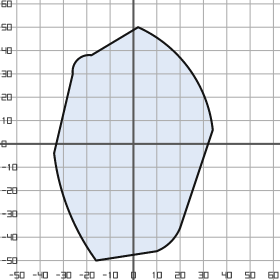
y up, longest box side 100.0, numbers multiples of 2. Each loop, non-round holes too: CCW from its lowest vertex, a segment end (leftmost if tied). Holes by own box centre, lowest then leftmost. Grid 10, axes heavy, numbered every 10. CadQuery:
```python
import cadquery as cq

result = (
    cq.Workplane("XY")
    .moveTo(-16.0, -50.0)
    .lineTo(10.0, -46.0)
    .threePointArc((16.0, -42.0), (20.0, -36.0))
    .lineTo(34.0, 6.0)
    .threePointArc((24.0, 32.0), (2.0, 50.0))
    .lineTo(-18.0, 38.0)
    .threePointArc((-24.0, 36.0), (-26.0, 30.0))
    .lineTo(-34.0, -4.0)
    .threePointArc((-28.0, -28.0), (-16.0, -50.0))
    .close()
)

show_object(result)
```